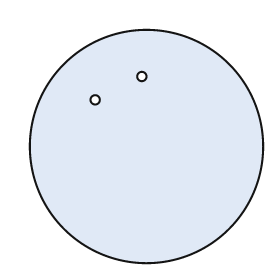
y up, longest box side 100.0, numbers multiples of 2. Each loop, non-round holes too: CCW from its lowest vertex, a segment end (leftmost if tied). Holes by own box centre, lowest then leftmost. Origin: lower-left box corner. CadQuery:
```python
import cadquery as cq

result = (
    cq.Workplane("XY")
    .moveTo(50.0, 50.0)
    .circle(50.0)
    .moveTo(28.0, 70.0)
    .circle(2.0)
    .moveTo(48.0, 80.0)
    .circle(2.0)
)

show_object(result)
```